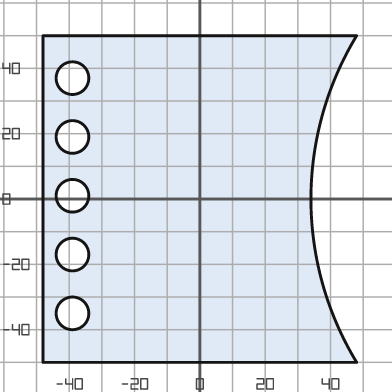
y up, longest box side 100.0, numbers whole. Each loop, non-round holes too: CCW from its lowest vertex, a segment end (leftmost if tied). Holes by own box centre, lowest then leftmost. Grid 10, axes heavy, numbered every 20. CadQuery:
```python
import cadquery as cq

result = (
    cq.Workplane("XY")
    .moveTo(-48.0, -50.0)
    .lineTo(48.0, -50.0)
    .threePointArc((34.0, 0.0), (48.0, 50.0))
    .lineTo(-48.0, 50.0)
    .close()
    .moveTo(-39.0, -35.0)
    .circle(5.0)
    .moveTo(-39.0, -17.0)
    .circle(5.0)
    .moveTo(-39.0, 1.0)
    .circle(5.0)
    .moveTo(-39.0, 19.0)
    .circle(5.0)
    .moveTo(-39.0, 37.0)
    .circle(5.0)
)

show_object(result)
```